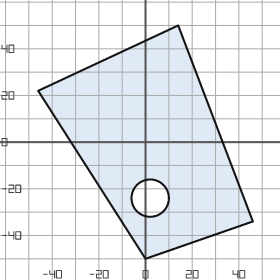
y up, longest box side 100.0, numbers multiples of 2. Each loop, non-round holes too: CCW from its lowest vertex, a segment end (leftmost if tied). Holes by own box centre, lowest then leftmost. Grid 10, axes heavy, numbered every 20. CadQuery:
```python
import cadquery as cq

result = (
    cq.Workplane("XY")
    .moveTo(0.0, -50.0)
    .lineTo(46.0, -34.0)
    .lineTo(14.0, 50.0)
    .lineTo(-46.0, 22.0)
    .close()
    .moveTo(2.0, -24.0)
    .circle(8.0)
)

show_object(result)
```